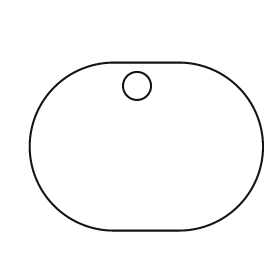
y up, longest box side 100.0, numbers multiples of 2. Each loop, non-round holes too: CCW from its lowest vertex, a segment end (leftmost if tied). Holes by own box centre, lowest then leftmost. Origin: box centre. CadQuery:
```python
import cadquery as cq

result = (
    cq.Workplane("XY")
    .moveTo(-14.0, -36.0)
    .lineTo(14.0, -36.0)
    .threePointArc((50.0, 0.0), (14.0, 36.0))
    .lineTo(-14.0, 36.0)
    .threePointArc((-50.0, 0.0), (-14.0, -36.0))
    .close()
    .moveTo(-4.0, 26.0)
    .circle(6.0)
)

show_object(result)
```